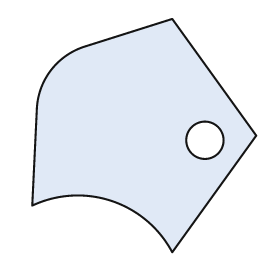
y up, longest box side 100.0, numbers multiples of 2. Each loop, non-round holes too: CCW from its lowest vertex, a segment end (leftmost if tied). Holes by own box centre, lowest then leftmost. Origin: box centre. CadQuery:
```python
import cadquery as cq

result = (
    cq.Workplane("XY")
    .moveTo(12.0, -50.0)
    .lineTo(48.0, 0.0)
    .lineTo(12.0, 50.0)
    .lineTo(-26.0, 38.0)
    .threePointArc((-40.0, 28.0), (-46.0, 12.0))
    .lineTo(-48.0, -30.0)
    .threePointArc((-14.0, -28.0), (12.0, -50.0))
    .close()
    .moveTo(26.0, -2.0)
    .circle(8.0)
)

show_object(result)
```